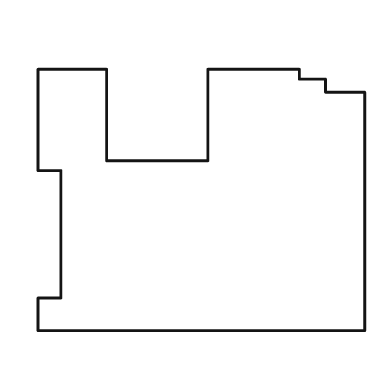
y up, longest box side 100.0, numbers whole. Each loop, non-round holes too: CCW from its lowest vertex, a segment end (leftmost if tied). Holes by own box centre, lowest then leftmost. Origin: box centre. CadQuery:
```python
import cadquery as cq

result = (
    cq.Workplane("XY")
    .moveTo(-50.0, -40.0)
    .lineTo(50.0, -40.0)
    .lineTo(50.0, 33.0)
    .lineTo(38.0, 33.0)
    .lineTo(38.0, 37.0)
    .lineTo(30.0, 37.0)
    .lineTo(30.0, 40.0)
    .lineTo(2.0, 40.0)
    .lineTo(2.0, 12.0)
    .lineTo(-29.0, 12.0)
    .lineTo(-29.0, 40.0)
    .lineTo(-50.0, 40.0)
    .lineTo(-50.0, 9.0)
    .lineTo(-43.0, 9.0)
    .lineTo(-43.0, -30.0)
    .lineTo(-50.0, -30.0)
    .close()
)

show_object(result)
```